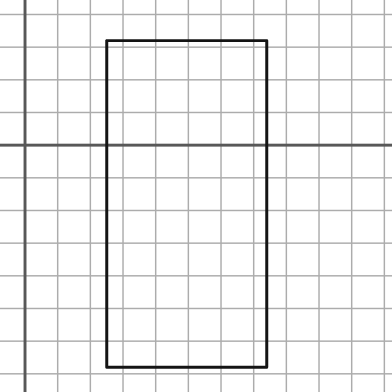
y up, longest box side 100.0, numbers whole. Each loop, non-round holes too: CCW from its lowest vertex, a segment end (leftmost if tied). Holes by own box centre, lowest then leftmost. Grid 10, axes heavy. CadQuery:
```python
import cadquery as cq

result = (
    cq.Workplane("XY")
    .moveTo(25.0, -68.0)
    .lineTo(74.0, -68.0)
    .lineTo(74.0, 32.0)
    .lineTo(25.0, 32.0)
    .close()
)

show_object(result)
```